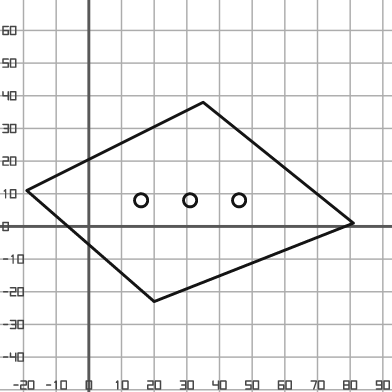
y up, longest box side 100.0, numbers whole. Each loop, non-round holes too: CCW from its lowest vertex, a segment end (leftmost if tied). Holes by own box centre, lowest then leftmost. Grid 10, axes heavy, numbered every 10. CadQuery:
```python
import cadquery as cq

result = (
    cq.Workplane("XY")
    .moveTo(20.0, -23.0)
    .lineTo(81.0, 1.0)
    .lineTo(35.0, 38.0)
    .lineTo(-19.0, 11.0)
    .close()
    .moveTo(16.0, 8.0)
    .circle(2.0)
    .moveTo(31.0, 8.0)
    .circle(2.0)
    .moveTo(46.0, 8.0)
    .circle(2.0)
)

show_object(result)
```